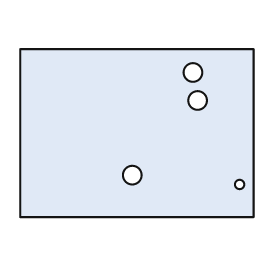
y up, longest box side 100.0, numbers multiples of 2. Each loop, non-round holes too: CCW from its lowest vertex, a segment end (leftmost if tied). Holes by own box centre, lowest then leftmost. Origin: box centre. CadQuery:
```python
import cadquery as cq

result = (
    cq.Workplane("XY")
    .moveTo(-50.0, -36.0)
    .lineTo(50.0, -36.0)
    .lineTo(50.0, 36.0)
    .lineTo(-50.0, 36.0)
    .close()
    .moveTo(44.0, -22.0)
    .circle(2.0)
    .moveTo(-2.0, -18.0)
    .circle(4.0)
    .moveTo(26.0, 14.0)
    .circle(4.0)
    .moveTo(24.0, 26.0)
    .circle(4.0)
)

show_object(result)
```